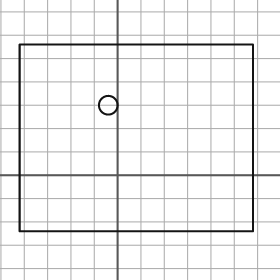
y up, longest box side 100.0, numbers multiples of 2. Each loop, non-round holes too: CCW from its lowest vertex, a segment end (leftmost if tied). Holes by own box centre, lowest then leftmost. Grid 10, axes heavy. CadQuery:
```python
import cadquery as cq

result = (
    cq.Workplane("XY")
    .moveTo(-42.0, -24.0)
    .lineTo(58.0, -24.0)
    .lineTo(58.0, 56.0)
    .lineTo(-42.0, 56.0)
    .close()
    .moveTo(-4.0, 30.0)
    .circle(4.0)
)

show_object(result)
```